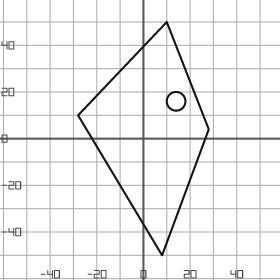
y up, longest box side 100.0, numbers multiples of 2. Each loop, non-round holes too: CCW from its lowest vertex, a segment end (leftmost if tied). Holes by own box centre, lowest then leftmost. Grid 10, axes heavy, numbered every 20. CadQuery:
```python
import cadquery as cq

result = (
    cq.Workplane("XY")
    .moveTo(8.0, -50.0)
    .lineTo(28.0, 4.0)
    .lineTo(10.0, 50.0)
    .lineTo(-28.0, 10.0)
    .close()
    .moveTo(14.0, 16.0)
    .circle(4.0)
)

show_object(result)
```